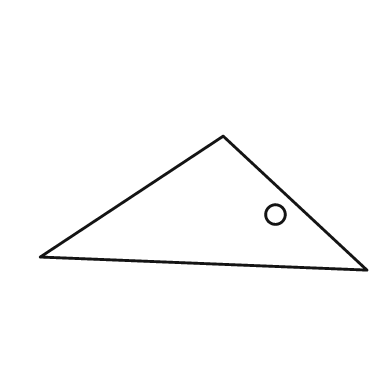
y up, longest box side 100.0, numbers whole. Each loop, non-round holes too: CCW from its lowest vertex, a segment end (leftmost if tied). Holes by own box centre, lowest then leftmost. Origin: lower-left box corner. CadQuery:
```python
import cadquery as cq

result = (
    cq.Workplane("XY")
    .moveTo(100.0, 0.0)
    .lineTo(56.0, 41.0)
    .lineTo(0.0, 4.0)
    .close()
    .moveTo(72.0, 17.0)
    .circle(3.0)
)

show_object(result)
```